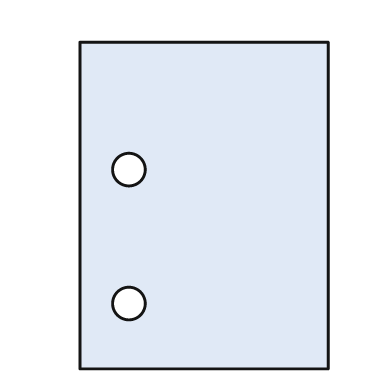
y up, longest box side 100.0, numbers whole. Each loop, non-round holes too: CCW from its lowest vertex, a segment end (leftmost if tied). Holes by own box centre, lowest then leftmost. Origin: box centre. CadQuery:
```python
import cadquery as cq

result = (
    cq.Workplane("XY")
    .moveTo(-38.0, -50.0)
    .lineTo(38.0, -50.0)
    .lineTo(38.0, 50.0)
    .lineTo(-38.0, 50.0)
    .close()
    .moveTo(-23.0, -30.0)
    .circle(5.0)
    .moveTo(-23.0, 11.0)
    .circle(5.0)
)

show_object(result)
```